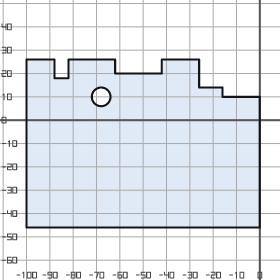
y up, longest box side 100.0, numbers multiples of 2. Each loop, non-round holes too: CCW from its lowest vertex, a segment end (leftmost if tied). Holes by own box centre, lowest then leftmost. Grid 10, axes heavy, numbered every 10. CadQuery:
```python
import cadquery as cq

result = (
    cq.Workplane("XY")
    .moveTo(-100.0, -46.0)
    .lineTo(0.0, -46.0)
    .lineTo(0.0, 10.0)
    .lineTo(-16.0, 10.0)
    .lineTo(-16.0, 14.0)
    .lineTo(-26.0, 14.0)
    .lineTo(-26.0, 26.0)
    .lineTo(-42.0, 26.0)
    .lineTo(-42.0, 20.0)
    .lineTo(-62.0, 20.0)
    .lineTo(-62.0, 26.0)
    .lineTo(-82.0, 26.0)
    .lineTo(-82.0, 18.0)
    .lineTo(-88.0, 18.0)
    .lineTo(-88.0, 26.0)
    .lineTo(-100.0, 26.0)
    .close()
    .moveTo(-68.0, 10.0)
    .circle(4.0)
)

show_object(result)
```